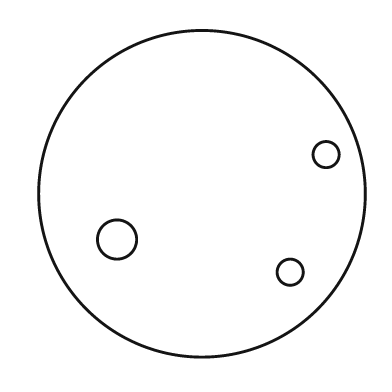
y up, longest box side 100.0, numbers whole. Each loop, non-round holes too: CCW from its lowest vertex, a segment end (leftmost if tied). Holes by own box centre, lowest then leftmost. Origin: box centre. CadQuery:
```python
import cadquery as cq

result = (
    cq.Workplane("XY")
    .moveTo(0.0, 0.0)
    .circle(50.0)
    .moveTo(27.0, -24.0)
    .circle(4.0)
    .moveTo(-26.0, -14.0)
    .circle(6.0)
    .moveTo(38.0, 12.0)
    .circle(4.0)
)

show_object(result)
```